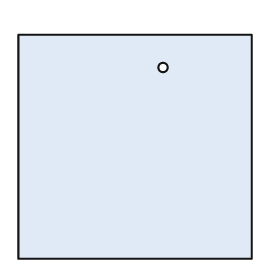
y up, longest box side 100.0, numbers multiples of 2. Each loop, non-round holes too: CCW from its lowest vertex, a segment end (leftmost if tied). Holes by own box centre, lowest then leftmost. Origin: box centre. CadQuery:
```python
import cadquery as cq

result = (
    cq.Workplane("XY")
    .moveTo(-50.0, -48.0)
    .lineTo(50.0, -48.0)
    .lineTo(50.0, 48.0)
    .lineTo(-50.0, 48.0)
    .close()
    .moveTo(12.0, 34.0)
    .circle(2.0)
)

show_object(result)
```